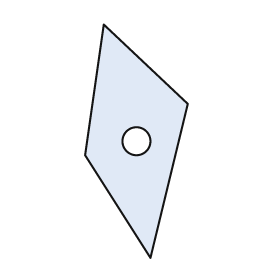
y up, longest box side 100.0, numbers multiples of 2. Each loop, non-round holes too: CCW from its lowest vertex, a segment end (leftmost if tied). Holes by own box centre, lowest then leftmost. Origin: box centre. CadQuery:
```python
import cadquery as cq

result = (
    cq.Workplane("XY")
    .moveTo(6.0, -50.0)
    .lineTo(22.0, 16.0)
    .lineTo(-14.0, 50.0)
    .lineTo(-22.0, -6.0)
    .close()
    .moveTo(0.0, 0.0)
    .circle(6.0)
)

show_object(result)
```